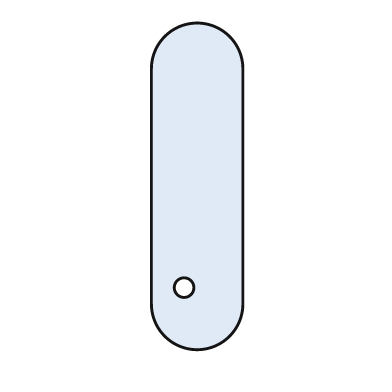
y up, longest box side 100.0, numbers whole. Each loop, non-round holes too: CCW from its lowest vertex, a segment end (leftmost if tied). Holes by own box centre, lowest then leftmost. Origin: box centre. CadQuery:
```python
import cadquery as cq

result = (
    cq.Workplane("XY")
    .moveTo(-14.0, -36.0)
    .threePointArc((0.0, -50.0), (14.0, -36.0))
    .lineTo(14.0, 36.0)
    .threePointArc((0.0, 50.0), (-14.0, 36.0))
    .close()
    .moveTo(-4.0, -31.0)
    .circle(3.0)
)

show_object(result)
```